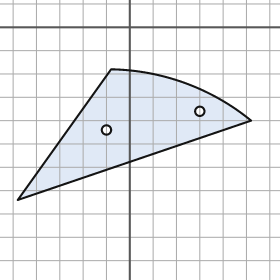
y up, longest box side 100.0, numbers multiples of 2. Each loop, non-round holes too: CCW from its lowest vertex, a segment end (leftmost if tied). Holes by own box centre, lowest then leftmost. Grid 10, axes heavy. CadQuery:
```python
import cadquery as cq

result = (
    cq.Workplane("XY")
    .moveTo(-48.0, -74.0)
    .lineTo(52.0, -40.0)
    .threePointArc((24.0, -24.0), (-8.0, -18.0))
    .close()
    .moveTo(-10.0, -44.0)
    .circle(2.0)
    .moveTo(30.0, -36.0)
    .circle(2.0)
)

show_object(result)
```